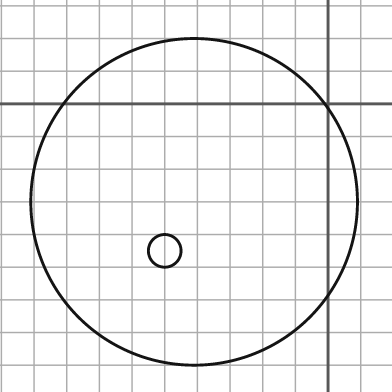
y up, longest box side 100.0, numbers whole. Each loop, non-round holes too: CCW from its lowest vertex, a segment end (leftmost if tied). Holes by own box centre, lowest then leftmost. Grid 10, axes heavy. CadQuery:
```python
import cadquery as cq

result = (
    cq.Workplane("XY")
    .moveTo(-41.0, -30.0)
    .circle(50.0)
    .moveTo(-50.0, -45.0)
    .circle(5.0)
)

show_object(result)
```